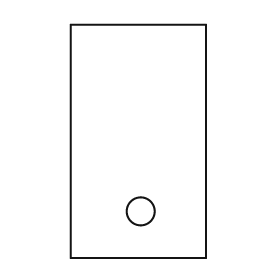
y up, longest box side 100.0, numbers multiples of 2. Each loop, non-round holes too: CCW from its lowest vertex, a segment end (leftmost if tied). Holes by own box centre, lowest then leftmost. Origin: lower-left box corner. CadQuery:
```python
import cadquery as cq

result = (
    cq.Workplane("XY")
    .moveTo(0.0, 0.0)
    .lineTo(58.0, 0.0)
    .lineTo(58.0, 100.0)
    .lineTo(0.0, 100.0)
    .close()
    .moveTo(30.0, 20.0)
    .circle(6.0)
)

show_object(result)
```